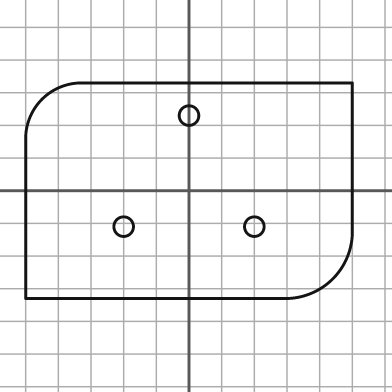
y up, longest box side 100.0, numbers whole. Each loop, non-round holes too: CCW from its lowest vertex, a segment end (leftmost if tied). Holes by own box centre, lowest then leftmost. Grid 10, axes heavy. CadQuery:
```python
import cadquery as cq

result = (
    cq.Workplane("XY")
    .moveTo(-50.0, -33.0)
    .lineTo(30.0, -33.0)
    .threePointArc((44.0, -27.0), (50.0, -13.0))
    .lineTo(50.0, 33.0)
    .lineTo(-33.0, 33.0)
    .threePointArc((-45.0, 28.0), (-50.0, 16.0))
    .close()
    .moveTo(-20.0, -11.0)
    .circle(3.0)
    .moveTo(20.0, -11.0)
    .circle(3.0)
    .moveTo(0.0, 23.0)
    .circle(3.0)
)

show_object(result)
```